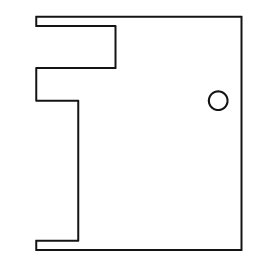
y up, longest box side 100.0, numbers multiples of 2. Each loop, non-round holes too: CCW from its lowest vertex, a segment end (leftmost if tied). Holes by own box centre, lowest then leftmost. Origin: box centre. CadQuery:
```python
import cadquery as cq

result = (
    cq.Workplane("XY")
    .moveTo(-44.0, -50.0)
    .lineTo(44.0, -50.0)
    .lineTo(44.0, 50.0)
    .lineTo(-44.0, 50.0)
    .lineTo(-44.0, 46.0)
    .lineTo(-10.0, 46.0)
    .lineTo(-10.0, 28.0)
    .lineTo(-44.0, 28.0)
    .lineTo(-44.0, 14.0)
    .lineTo(-26.0, 14.0)
    .lineTo(-26.0, -46.0)
    .lineTo(-44.0, -46.0)
    .close()
    .moveTo(34.0, 14.0)
    .circle(4.0)
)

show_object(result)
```